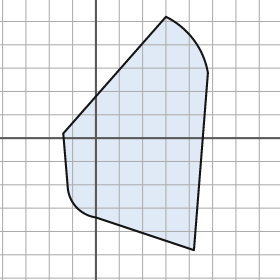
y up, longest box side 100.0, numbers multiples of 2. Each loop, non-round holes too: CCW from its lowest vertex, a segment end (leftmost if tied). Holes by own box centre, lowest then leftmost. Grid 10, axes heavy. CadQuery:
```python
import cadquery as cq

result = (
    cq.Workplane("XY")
    .moveTo(42.0, -48.0)
    .lineTo(48.0, 28.0)
    .threePointArc((42.0, 42.0), (30.0, 52.0))
    .lineTo(-14.0, 2.0)
    .lineTo(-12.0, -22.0)
    .threePointArc((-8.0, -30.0), (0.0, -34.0))
    .close()
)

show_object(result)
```